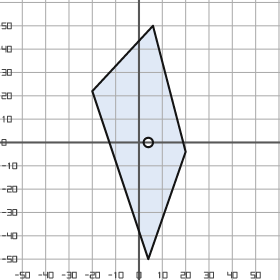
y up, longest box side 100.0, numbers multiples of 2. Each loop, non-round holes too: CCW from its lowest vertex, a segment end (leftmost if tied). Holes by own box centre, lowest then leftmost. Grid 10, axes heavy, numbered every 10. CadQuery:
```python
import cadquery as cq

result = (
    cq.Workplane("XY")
    .moveTo(4.0, -50.0)
    .lineTo(20.0, -4.0)
    .lineTo(6.0, 50.0)
    .lineTo(-20.0, 22.0)
    .close()
    .moveTo(4.0, 0.0)
    .circle(2.0)
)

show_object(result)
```